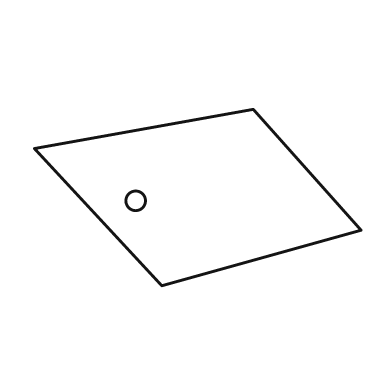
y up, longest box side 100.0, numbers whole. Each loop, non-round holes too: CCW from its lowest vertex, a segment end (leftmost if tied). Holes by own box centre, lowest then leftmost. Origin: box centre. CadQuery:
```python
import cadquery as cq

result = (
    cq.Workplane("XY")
    .moveTo(-11.0, -27.0)
    .lineTo(50.0, -10.0)
    .lineTo(17.0, 27.0)
    .lineTo(-50.0, 15.0)
    .close()
    .moveTo(-19.0, -1.0)
    .circle(3.0)
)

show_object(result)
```